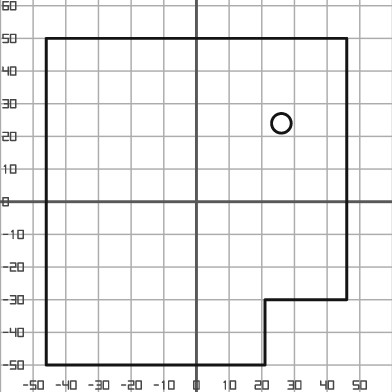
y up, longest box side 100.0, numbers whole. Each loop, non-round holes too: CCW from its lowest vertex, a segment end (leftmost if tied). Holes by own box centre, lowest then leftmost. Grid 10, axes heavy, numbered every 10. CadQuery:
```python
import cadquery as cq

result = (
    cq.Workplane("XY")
    .moveTo(-46.0, -50.0)
    .lineTo(21.0, -50.0)
    .lineTo(21.0, -30.0)
    .lineTo(46.0, -30.0)
    .lineTo(46.0, 50.0)
    .lineTo(-46.0, 50.0)
    .close()
    .moveTo(26.0, 24.0)
    .circle(3.0)
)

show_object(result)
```